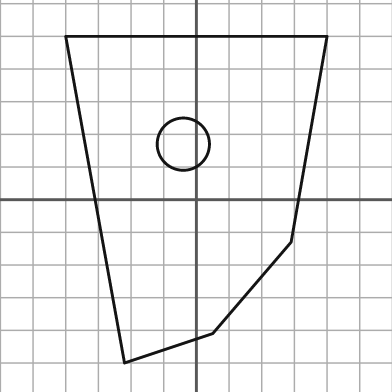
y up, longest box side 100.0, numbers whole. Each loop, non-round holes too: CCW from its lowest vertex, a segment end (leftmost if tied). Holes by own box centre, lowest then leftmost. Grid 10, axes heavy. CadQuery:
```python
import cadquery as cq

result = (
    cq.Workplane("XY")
    .moveTo(-22.0, -50.0)
    .lineTo(5.0, -41.0)
    .lineTo(29.0, -13.0)
    .lineTo(40.0, 50.0)
    .lineTo(-40.0, 50.0)
    .close()
    .moveTo(-4.0, 17.0)
    .circle(8.0)
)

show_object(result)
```